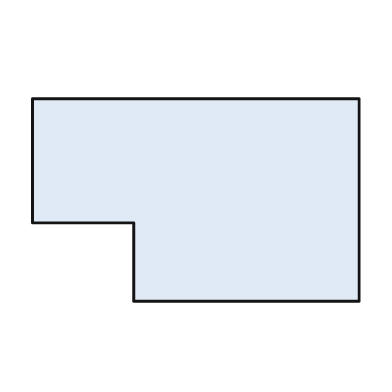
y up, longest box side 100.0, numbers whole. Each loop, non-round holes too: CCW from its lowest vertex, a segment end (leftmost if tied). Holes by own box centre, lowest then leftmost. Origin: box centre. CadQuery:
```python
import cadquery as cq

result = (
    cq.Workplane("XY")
    .moveTo(-19.0, -31.0)
    .lineTo(50.0, -31.0)
    .lineTo(50.0, 31.0)
    .lineTo(-50.0, 31.0)
    .lineTo(-50.0, -7.0)
    .lineTo(-19.0, -7.0)
    .close()
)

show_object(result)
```